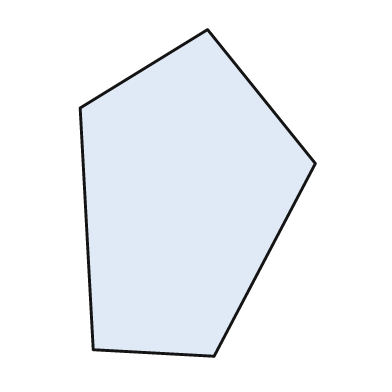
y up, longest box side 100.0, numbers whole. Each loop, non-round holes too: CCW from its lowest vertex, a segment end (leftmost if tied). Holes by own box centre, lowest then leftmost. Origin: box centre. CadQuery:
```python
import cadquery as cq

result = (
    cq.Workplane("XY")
    .moveTo(5.0, -50.0)
    .lineTo(36.0, 9.0)
    .lineTo(3.0, 50.0)
    .lineTo(-36.0, 26.0)
    .lineTo(-32.0, -48.0)
    .close()
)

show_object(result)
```